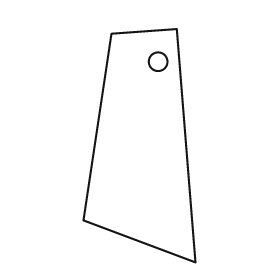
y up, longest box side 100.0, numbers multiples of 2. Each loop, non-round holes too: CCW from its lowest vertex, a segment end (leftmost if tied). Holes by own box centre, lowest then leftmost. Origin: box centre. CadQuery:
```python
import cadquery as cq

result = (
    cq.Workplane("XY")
    .moveTo(24.0, -50.0)
    .lineTo(16.0, 50.0)
    .lineTo(-12.0, 48.0)
    .lineTo(-24.0, -32.0)
    .close()
    .moveTo(8.0, 36.0)
    .circle(4.0)
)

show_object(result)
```